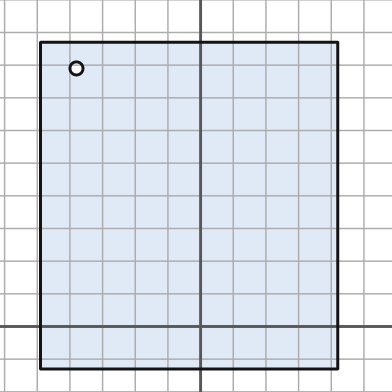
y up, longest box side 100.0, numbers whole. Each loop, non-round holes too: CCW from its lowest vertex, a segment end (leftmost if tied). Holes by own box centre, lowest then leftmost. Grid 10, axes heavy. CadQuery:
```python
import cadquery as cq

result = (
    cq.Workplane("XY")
    .moveTo(-49.0, -13.0)
    .lineTo(42.0, -13.0)
    .lineTo(42.0, 87.0)
    .lineTo(-49.0, 87.0)
    .close()
    .moveTo(-38.0, 79.0)
    .circle(2.0)
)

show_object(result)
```